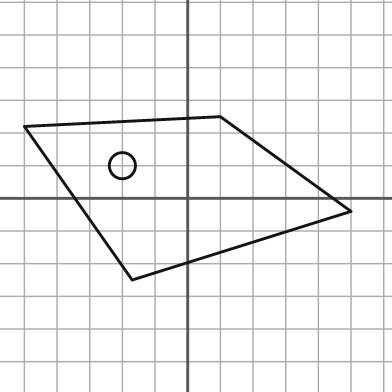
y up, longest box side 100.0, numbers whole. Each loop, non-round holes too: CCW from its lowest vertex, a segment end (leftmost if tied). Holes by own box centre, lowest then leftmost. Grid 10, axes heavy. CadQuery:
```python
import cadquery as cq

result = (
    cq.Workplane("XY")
    .moveTo(-17.0, -25.0)
    .lineTo(50.0, -4.0)
    .lineTo(10.0, 25.0)
    .lineTo(-50.0, 22.0)
    .close()
    .moveTo(-20.0, 10.0)
    .circle(4.0)
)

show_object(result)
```